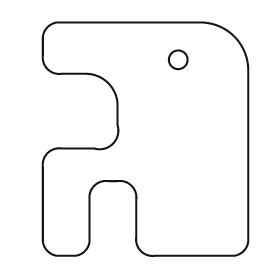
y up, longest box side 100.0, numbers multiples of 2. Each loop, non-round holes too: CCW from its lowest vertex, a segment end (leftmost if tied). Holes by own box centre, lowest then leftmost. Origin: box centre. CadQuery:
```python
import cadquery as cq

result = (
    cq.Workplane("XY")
    .moveTo(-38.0, -50.0)
    .lineTo(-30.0, -50.0)
    .threePointArc((-26.0, -48.0), (-24.0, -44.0))
    .lineTo(-24.0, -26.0)
    .threePointArc((-22.0, -20.0), (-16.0, -18.0))
    .lineTo(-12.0, -18.0)
    .threePointArc((-6.0, -20.0), (-4.0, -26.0))
    .lineTo(-4.0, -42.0)
    .threePointArc((-2.0, -48.0), (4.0, -50.0))
    .lineTo(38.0, -50.0)
    .threePointArc((42.0, -48.0), (44.0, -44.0))
    .lineTo(44.0, 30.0)
    .threePointArc((38.0, 44.0), (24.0, 50.0))
    .lineTo(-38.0, 50.0)
    .threePointArc((-42.0, 48.0), (-44.0, 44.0))
    .lineTo(-44.0, 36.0)
    .threePointArc((-42.0, 30.0), (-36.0, 28.0))
    .lineTo(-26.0, 28.0)
    .threePointArc((-16.0, 24.0), (-12.0, 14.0))
    .lineTo(-12.0, 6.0)
    .threePointArc((-14.0, -2.0), (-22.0, -4.0))
    .lineTo(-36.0, -4.0)
    .threePointArc((-42.0, -6.0), (-44.0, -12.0))
    .lineTo(-44.0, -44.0)
    .threePointArc((-42.0, -48.0), (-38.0, -50.0))
    .close()
    .moveTo(14.0, 34.0)
    .circle(4.0)
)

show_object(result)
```